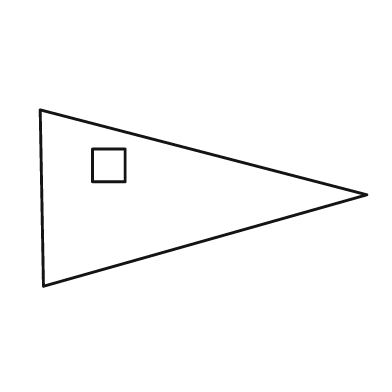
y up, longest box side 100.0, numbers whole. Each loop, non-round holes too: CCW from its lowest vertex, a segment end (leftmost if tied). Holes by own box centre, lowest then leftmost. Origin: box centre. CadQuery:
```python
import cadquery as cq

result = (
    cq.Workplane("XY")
    .moveTo(-49.0, -27.0)
    .lineTo(50.0, 1.0)
    .lineTo(-50.0, 27.0)
    .close()
    .moveTo(-34.0, 5.0)
    .lineTo(-24.0, 5.0)
    .lineTo(-24.0, 15.0)
    .lineTo(-34.0, 15.0)
    .close()
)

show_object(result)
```